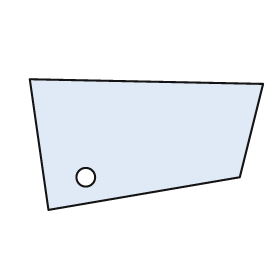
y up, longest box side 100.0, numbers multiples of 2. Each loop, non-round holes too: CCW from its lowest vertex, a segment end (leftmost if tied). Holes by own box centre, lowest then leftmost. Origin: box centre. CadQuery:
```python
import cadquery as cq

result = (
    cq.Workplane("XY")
    .moveTo(-42.0, -28.0)
    .lineTo(40.0, -14.0)
    .lineTo(50.0, 26.0)
    .lineTo(-50.0, 28.0)
    .close()
    .moveTo(-26.0, -14.0)
    .circle(4.0)
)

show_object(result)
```